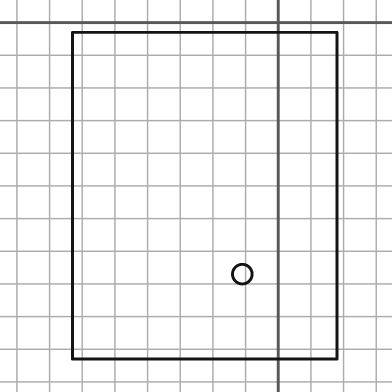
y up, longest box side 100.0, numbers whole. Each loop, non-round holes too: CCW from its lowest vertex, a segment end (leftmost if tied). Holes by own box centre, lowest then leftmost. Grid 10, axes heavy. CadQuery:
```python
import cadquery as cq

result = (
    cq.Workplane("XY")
    .moveTo(-63.0, -103.0)
    .lineTo(18.0, -103.0)
    .lineTo(18.0, -3.0)
    .lineTo(-63.0, -3.0)
    .close()
    .moveTo(-11.0, -77.0)
    .circle(3.0)
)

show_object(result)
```